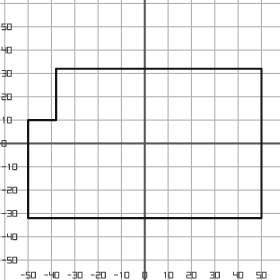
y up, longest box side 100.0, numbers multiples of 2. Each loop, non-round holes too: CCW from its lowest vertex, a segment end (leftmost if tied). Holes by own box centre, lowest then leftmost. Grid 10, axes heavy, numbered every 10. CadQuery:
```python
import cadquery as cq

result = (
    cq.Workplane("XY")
    .moveTo(-50.0, -32.0)
    .lineTo(50.0, -32.0)
    .lineTo(50.0, 32.0)
    .lineTo(-38.0, 32.0)
    .lineTo(-38.0, 10.0)
    .lineTo(-50.0, 10.0)
    .close()
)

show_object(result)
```